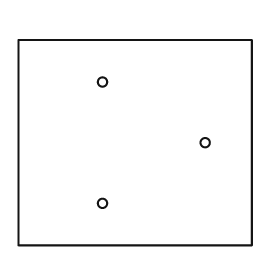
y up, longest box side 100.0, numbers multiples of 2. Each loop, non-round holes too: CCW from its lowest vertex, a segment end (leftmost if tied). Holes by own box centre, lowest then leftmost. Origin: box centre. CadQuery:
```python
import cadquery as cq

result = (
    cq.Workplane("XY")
    .moveTo(-50.0, -44.0)
    .lineTo(50.0, -44.0)
    .lineTo(50.0, 44.0)
    .lineTo(-50.0, 44.0)
    .close()
    .moveTo(-14.0, -26.0)
    .circle(2.0)
    .moveTo(30.0, 0.0)
    .circle(2.0)
    .moveTo(-14.0, 26.0)
    .circle(2.0)
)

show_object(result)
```